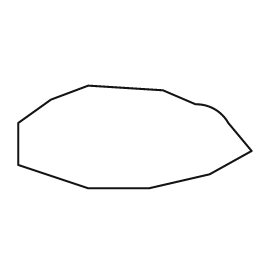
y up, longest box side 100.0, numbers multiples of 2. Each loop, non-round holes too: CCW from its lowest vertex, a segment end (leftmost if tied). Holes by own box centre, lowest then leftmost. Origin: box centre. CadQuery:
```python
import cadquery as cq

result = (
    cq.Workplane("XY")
    .moveTo(-20.0, -22.0)
    .lineTo(6.0, -22.0)
    .lineTo(32.0, -16.0)
    .lineTo(50.0, -6.0)
    .lineTo(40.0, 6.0)
    .threePointArc((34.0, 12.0), (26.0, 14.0))
    .lineTo(12.0, 20.0)
    .lineTo(-20.0, 22.0)
    .lineTo(-36.0, 16.0)
    .lineTo(-50.0, 6.0)
    .lineTo(-50.0, -12.0)
    .close()
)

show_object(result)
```